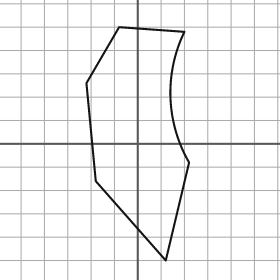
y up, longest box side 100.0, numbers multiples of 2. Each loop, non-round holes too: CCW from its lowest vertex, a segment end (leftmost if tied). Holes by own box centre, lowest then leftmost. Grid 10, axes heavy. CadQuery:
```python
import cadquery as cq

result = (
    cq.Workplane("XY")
    .moveTo(12.0, -50.0)
    .lineTo(22.0, -8.0)
    .threePointArc((14.0, 20.0), (20.0, 48.0))
    .lineTo(-8.0, 50.0)
    .lineTo(-22.0, 26.0)
    .lineTo(-18.0, -16.0)
    .close()
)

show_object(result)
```